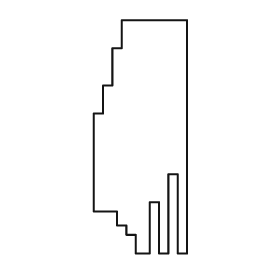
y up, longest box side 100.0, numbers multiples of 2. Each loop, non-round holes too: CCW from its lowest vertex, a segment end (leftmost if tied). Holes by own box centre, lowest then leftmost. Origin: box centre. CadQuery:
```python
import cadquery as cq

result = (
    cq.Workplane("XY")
    .moveTo(-2.0, -50.0)
    .lineTo(4.0, -50.0)
    .lineTo(4.0, -28.0)
    .lineTo(8.0, -28.0)
    .lineTo(8.0, -50.0)
    .lineTo(12.0, -50.0)
    .lineTo(12.0, -16.0)
    .lineTo(16.0, -16.0)
    .lineTo(16.0, -50.0)
    .lineTo(20.0, -50.0)
    .lineTo(20.0, 50.0)
    .lineTo(-8.0, 50.0)
    .lineTo(-8.0, 38.0)
    .lineTo(-12.0, 38.0)
    .lineTo(-12.0, 22.0)
    .lineTo(-16.0, 22.0)
    .lineTo(-16.0, 10.0)
    .lineTo(-20.0, 10.0)
    .lineTo(-20.0, -32.0)
    .lineTo(-10.0, -32.0)
    .lineTo(-10.0, -38.0)
    .lineTo(-6.0, -38.0)
    .lineTo(-6.0, -42.0)
    .lineTo(-2.0, -42.0)
    .close()
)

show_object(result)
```